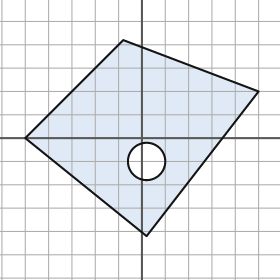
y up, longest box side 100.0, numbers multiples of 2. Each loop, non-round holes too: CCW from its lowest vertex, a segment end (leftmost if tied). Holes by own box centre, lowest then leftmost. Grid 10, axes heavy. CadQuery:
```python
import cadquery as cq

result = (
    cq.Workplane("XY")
    .moveTo(2.0, -42.0)
    .lineTo(50.0, 20.0)
    .lineTo(-8.0, 42.0)
    .lineTo(-50.0, 0.0)
    .close()
    .moveTo(2.0, -10.0)
    .circle(8.0)
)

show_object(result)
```